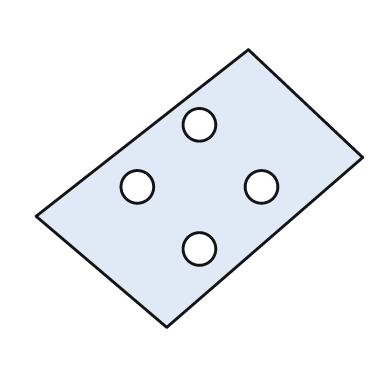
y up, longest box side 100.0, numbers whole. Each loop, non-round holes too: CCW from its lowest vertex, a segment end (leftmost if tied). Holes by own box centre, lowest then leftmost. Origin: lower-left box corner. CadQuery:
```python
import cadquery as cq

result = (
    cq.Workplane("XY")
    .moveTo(40.0, 0.0)
    .lineTo(100.0, 52.0)
    .lineTo(65.0, 85.0)
    .lineTo(0.0, 34.0)
    .close()
    .moveTo(50.0, 24.0)
    .circle(5.0)
    .moveTo(31.0, 43.0)
    .circle(5.0)
    .moveTo(69.0, 43.0)
    .circle(5.0)
    .moveTo(50.0, 62.0)
    .circle(5.0)
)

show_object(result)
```